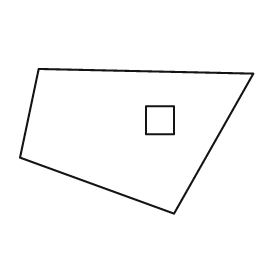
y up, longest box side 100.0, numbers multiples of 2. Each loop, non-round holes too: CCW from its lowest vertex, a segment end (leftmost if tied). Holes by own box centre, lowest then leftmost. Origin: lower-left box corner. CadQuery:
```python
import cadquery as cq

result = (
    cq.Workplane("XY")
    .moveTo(66.0, 0.0)
    .lineTo(100.0, 60.0)
    .lineTo(8.0, 62.0)
    .lineTo(0.0, 24.0)
    .close()
    .moveTo(54.0, 34.0)
    .lineTo(66.0, 34.0)
    .lineTo(66.0, 46.0)
    .lineTo(54.0, 46.0)
    .close()
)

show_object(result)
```